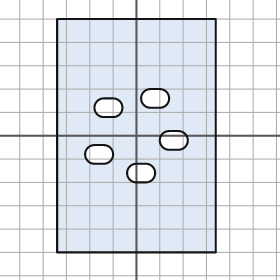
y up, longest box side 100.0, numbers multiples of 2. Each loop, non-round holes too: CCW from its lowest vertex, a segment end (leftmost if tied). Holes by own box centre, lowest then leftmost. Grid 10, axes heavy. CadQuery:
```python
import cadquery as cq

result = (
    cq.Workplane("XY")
    .moveTo(-34.0, -50.0)
    .lineTo(34.0, -50.0)
    .lineTo(34.0, 50.0)
    .lineTo(-34.0, 50.0)
    .close()
    .moveTo(0.0, -20.0)
    .lineTo(4.0, -20.0)
    .threePointArc((8.0, -16.0), (4.0, -12.0))
    .lineTo(0.0, -12.0)
    .threePointArc((-4.0, -16.0), (0.0, -20.0))
    .close()
    .moveTo(-18.0, -12.0)
    .lineTo(-14.0, -12.0)
    .threePointArc((-10.0, -8.0), (-14.0, -4.0))
    .lineTo(-18.0, -4.0)
    .threePointArc((-22.0, -8.0), (-18.0, -12.0))
    .close()
    .moveTo(14.0, -6.0)
    .lineTo(18.0, -6.0)
    .threePointArc((22.0, -2.0), (18.0, 2.0))
    .lineTo(14.0, 2.0)
    .threePointArc((10.0, -2.0), (14.0, -6.0))
    .close()
    .moveTo(-14.0, 8.0)
    .lineTo(-10.0, 8.0)
    .threePointArc((-6.0, 12.0), (-10.0, 16.0))
    .lineTo(-14.0, 16.0)
    .threePointArc((-18.0, 12.0), (-14.0, 8.0))
    .close()
    .moveTo(6.0, 12.0)
    .lineTo(10.0, 12.0)
    .threePointArc((14.0, 16.0), (10.0, 20.0))
    .lineTo(6.0, 20.0)
    .threePointArc((2.0, 16.0), (6.0, 12.0))
    .close()
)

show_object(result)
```